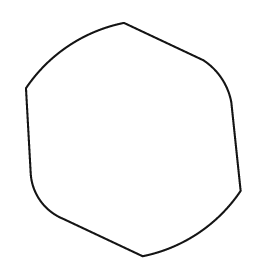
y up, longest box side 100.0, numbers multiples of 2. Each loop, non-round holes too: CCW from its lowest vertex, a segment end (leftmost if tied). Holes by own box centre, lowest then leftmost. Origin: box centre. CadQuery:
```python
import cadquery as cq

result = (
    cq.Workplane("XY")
    .moveTo(4.0, -50.0)
    .threePointArc((28.0, -40.0), (46.0, -22.0))
    .lineTo(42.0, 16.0)
    .threePointArc((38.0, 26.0), (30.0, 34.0))
    .lineTo(-4.0, 50.0)
    .threePointArc((-28.0, 40.0), (-46.0, 22.0))
    .lineTo(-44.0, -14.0)
    .threePointArc((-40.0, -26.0), (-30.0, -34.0))
    .close()
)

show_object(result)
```